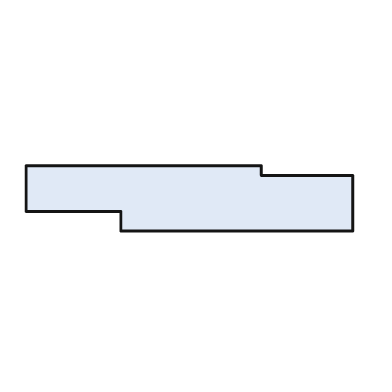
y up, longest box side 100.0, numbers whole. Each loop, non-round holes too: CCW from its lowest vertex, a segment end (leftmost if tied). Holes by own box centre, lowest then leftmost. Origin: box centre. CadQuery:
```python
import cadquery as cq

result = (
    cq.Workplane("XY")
    .moveTo(-21.0, -10.0)
    .lineTo(50.0, -10.0)
    .lineTo(50.0, 7.0)
    .lineTo(22.0, 7.0)
    .lineTo(22.0, 10.0)
    .lineTo(-50.0, 10.0)
    .lineTo(-50.0, -4.0)
    .lineTo(-21.0, -4.0)
    .close()
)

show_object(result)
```